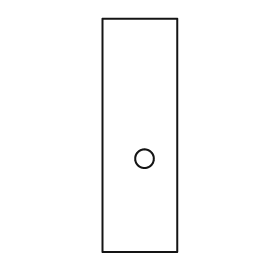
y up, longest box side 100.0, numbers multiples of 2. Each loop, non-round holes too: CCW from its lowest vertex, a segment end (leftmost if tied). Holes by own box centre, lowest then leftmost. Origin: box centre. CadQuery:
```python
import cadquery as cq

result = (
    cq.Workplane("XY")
    .moveTo(-16.0, -50.0)
    .lineTo(16.0, -50.0)
    .lineTo(16.0, 50.0)
    .lineTo(-16.0, 50.0)
    .close()
    .moveTo(2.0, -10.0)
    .circle(4.0)
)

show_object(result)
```